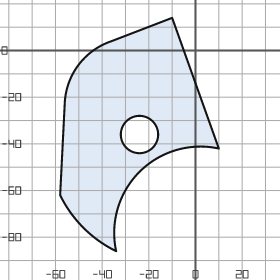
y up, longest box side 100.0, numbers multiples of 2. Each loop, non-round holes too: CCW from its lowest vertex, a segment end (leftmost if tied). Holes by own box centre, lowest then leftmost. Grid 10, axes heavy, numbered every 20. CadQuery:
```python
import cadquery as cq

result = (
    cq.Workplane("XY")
    .moveTo(-34.0, -86.0)
    .threePointArc((-24.0, -52.0), (10.0, -42.0))
    .lineTo(-10.0, 14.0)
    .lineTo(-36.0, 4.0)
    .threePointArc((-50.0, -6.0), (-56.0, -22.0))
    .lineTo(-58.0, -62.0)
    .threePointArc((-48.0, -76.0), (-34.0, -86.0))
    .close()
    .moveTo(-24.0, -36.0)
    .circle(8.0)
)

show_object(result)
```